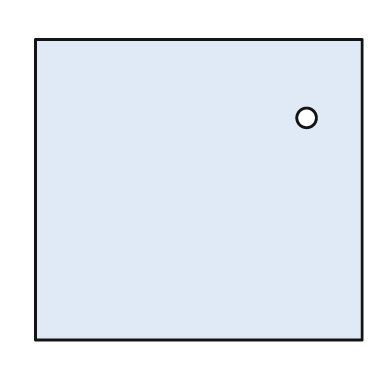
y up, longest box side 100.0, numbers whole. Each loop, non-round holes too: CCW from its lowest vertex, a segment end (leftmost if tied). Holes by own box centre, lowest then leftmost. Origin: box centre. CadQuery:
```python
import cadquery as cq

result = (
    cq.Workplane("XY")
    .moveTo(-50.0, -46.0)
    .lineTo(50.0, -46.0)
    .lineTo(50.0, 46.0)
    .lineTo(-50.0, 46.0)
    .close()
    .moveTo(33.0, 22.0)
    .circle(3.0)
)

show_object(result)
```